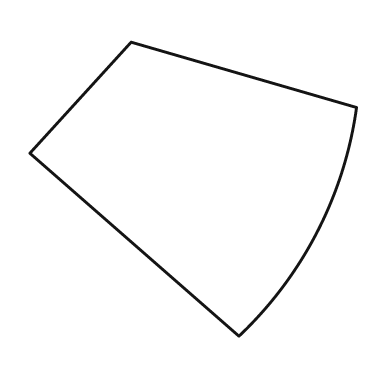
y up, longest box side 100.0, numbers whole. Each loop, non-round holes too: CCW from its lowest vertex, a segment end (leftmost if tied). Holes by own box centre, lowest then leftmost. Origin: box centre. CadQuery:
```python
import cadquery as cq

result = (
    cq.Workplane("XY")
    .moveTo(14.0, -45.0)
    .threePointArc((38.0, -13.0), (50.0, 25.0))
    .lineTo(-19.0, 45.0)
    .lineTo(-50.0, 11.0)
    .close()
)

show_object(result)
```